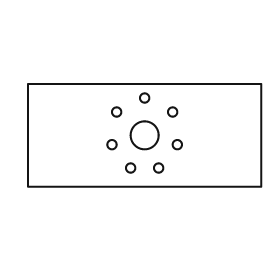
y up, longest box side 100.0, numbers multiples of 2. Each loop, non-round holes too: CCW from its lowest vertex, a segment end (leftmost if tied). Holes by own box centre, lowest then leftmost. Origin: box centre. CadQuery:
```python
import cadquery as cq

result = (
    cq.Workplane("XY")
    .moveTo(-50.0, -22.0)
    .lineTo(50.0, -22.0)
    .lineTo(50.0, 22.0)
    .lineTo(-50.0, 22.0)
    .close()
    .moveTo(-6.0, -14.0)
    .circle(2.0)
    .moveTo(6.0, -14.0)
    .circle(2.0)
    .moveTo(-14.0, -4.0)
    .circle(2.0)
    .moveTo(14.0, -4.0)
    .circle(2.0)
    .moveTo(0.0, 0.0)
    .circle(6.0)
    .moveTo(-12.0, 10.0)
    .circle(2.0)
    .moveTo(12.0, 10.0)
    .circle(2.0)
    .moveTo(0.0, 16.0)
    .circle(2.0)
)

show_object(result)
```